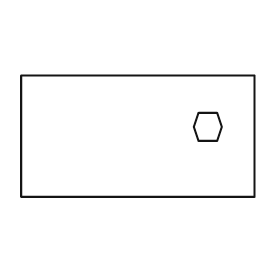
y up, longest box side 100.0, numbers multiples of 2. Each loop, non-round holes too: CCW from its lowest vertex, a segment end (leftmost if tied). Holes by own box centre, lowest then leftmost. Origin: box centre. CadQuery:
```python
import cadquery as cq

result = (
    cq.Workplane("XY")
    .moveTo(-50.0, -26.0)
    .lineTo(50.0, -26.0)
    .lineTo(50.0, 26.0)
    .lineTo(-50.0, 26.0)
    .close()
    .moveTo(26.0, -2.0)
    .lineTo(34.0, -2.0)
    .lineTo(36.0, 4.0)
    .lineTo(34.0, 10.0)
    .lineTo(26.0, 10.0)
    .lineTo(24.0, 4.0)
    .close()
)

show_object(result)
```